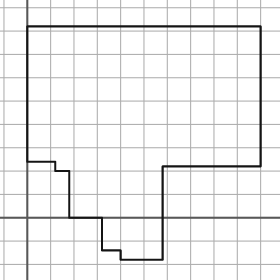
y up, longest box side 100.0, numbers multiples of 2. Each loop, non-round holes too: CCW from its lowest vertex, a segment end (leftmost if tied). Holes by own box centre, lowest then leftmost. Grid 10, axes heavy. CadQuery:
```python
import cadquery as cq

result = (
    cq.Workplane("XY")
    .moveTo(40.0, -18.0)
    .lineTo(58.0, -18.0)
    .lineTo(58.0, 22.0)
    .lineTo(100.0, 22.0)
    .lineTo(100.0, 82.0)
    .lineTo(0.0, 82.0)
    .lineTo(0.0, 24.0)
    .lineTo(12.0, 24.0)
    .lineTo(12.0, 20.0)
    .lineTo(18.0, 20.0)
    .lineTo(18.0, 0.0)
    .lineTo(32.0, 0.0)
    .lineTo(32.0, -14.0)
    .lineTo(40.0, -14.0)
    .close()
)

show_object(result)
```